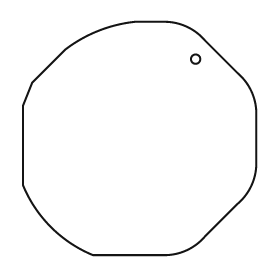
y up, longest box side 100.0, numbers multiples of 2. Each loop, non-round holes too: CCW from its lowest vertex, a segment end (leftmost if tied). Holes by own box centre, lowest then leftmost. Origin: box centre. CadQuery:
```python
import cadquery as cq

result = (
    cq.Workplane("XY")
    .moveTo(-20.0, -50.0)
    .lineTo(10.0, -50.0)
    .threePointArc((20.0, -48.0), (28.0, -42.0))
    .lineTo(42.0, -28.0)
    .threePointArc((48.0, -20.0), (50.0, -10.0))
    .lineTo(50.0, 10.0)
    .threePointArc((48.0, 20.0), (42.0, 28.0))
    .lineTo(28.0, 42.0)
    .threePointArc((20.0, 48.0), (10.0, 50.0))
    .lineTo(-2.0, 50.0)
    .threePointArc((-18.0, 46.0), (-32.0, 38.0))
    .lineTo(-46.0, 24.0)
    .lineTo(-50.0, 14.0)
    .lineTo(-50.0, -20.0)
    .threePointArc((-38.0, -38.0), (-20.0, -50.0))
    .close()
    .moveTo(24.0, 34.0)
    .circle(2.0)
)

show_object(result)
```